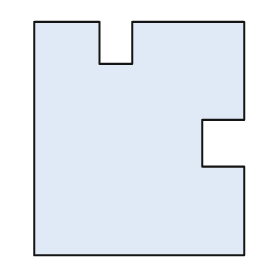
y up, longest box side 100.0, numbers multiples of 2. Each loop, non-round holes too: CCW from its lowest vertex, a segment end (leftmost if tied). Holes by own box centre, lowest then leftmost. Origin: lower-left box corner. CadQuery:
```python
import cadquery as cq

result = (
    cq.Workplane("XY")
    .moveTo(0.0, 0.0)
    .lineTo(90.0, 0.0)
    .lineTo(90.0, 38.0)
    .lineTo(72.0, 38.0)
    .lineTo(72.0, 58.0)
    .lineTo(90.0, 58.0)
    .lineTo(90.0, 100.0)
    .lineTo(42.0, 100.0)
    .lineTo(42.0, 82.0)
    .lineTo(28.0, 82.0)
    .lineTo(28.0, 100.0)
    .lineTo(0.0, 100.0)
    .close()
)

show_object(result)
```